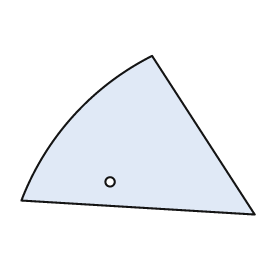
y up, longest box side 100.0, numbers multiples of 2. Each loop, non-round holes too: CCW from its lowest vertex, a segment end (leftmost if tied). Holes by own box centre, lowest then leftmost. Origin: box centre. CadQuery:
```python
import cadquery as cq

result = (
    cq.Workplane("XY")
    .moveTo(50.0, -34.0)
    .lineTo(6.0, 34.0)
    .threePointArc((-28.0, 8.0), (-50.0, -28.0))
    .close()
    .moveTo(-12.0, -20.0)
    .circle(2.0)
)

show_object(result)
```